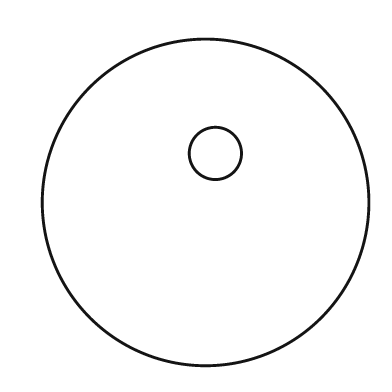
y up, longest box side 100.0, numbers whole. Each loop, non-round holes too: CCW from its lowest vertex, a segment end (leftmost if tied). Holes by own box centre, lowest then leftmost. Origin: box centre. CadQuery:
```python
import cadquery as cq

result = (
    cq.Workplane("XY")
    .moveTo(0.0, 0.0)
    .circle(50.0)
    .moveTo(3.0, 15.0)
    .circle(8.0)
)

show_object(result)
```